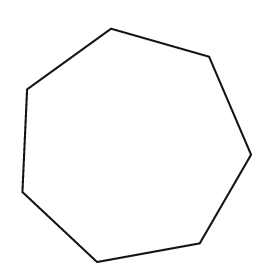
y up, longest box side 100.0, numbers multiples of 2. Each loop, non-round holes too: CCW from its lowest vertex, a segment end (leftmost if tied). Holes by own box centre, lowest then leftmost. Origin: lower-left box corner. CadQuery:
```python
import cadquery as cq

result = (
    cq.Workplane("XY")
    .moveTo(32.0, 0.0)
    .lineTo(76.0, 8.0)
    .lineTo(98.0, 46.0)
    .lineTo(80.0, 88.0)
    .lineTo(38.0, 100.0)
    .lineTo(2.0, 74.0)
    .lineTo(0.0, 30.0)
    .close()
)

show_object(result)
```